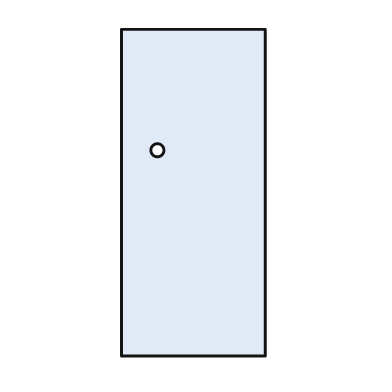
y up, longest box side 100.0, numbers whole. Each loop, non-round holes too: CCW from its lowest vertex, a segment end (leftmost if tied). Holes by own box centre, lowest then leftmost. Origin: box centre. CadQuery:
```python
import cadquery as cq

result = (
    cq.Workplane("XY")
    .moveTo(-22.0, -50.0)
    .lineTo(22.0, -50.0)
    .lineTo(22.0, 50.0)
    .lineTo(-22.0, 50.0)
    .close()
    .moveTo(-11.0, 13.0)
    .circle(2.0)
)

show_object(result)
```